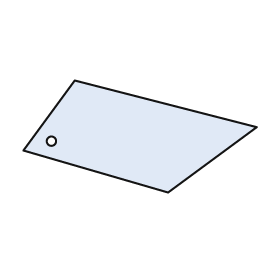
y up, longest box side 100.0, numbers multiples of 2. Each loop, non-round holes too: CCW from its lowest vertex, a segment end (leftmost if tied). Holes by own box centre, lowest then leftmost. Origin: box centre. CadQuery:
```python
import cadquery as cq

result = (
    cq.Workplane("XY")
    .moveTo(12.0, -24.0)
    .lineTo(50.0, 4.0)
    .lineTo(-28.0, 24.0)
    .lineTo(-50.0, -6.0)
    .close()
    .moveTo(-38.0, -2.0)
    .circle(2.0)
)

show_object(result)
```